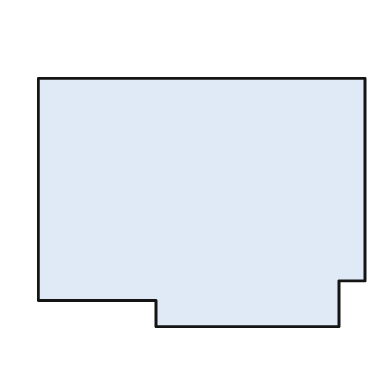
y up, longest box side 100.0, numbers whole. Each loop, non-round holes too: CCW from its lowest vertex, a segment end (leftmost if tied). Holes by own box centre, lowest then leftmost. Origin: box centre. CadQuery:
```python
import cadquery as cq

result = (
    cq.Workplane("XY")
    .moveTo(-14.0, -38.0)
    .lineTo(42.0, -38.0)
    .lineTo(42.0, -24.0)
    .lineTo(50.0, -24.0)
    .lineTo(50.0, 38.0)
    .lineTo(-50.0, 38.0)
    .lineTo(-50.0, -30.0)
    .lineTo(-14.0, -30.0)
    .close()
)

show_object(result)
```